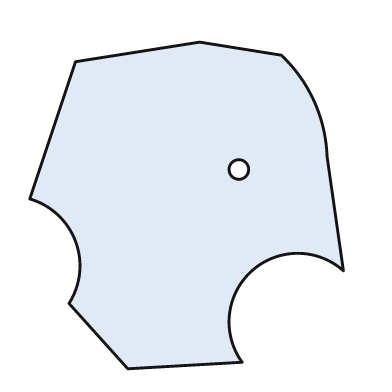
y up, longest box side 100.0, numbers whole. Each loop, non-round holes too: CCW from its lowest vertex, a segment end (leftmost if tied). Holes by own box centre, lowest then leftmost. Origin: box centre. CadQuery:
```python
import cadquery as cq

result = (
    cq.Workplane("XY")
    .moveTo(-18.0, -50.0)
    .lineTo(17.0, -48.0)
    .threePointArc((20.0, -20.0), (48.0, -20.0))
    .lineTo(43.0, 15.0)
    .threePointArc((39.0, 32.0), (29.0, 46.0))
    .lineTo(4.0, 50.0)
    .lineTo(-34.0, 44.0)
    .lineTo(-48.0, 2.0)
    .threePointArc((-34.0, -11.0), (-36.0, -30.0))
    .close()
    .moveTo(16.0, 11.0)
    .circle(3.0)
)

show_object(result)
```